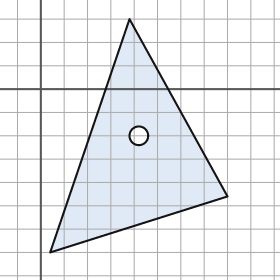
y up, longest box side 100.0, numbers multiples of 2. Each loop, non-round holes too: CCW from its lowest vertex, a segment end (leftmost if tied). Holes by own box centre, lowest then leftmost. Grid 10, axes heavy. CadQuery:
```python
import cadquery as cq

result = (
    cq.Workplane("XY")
    .moveTo(4.0, -70.0)
    .lineTo(80.0, -46.0)
    .lineTo(38.0, 30.0)
    .close()
    .moveTo(42.0, -20.0)
    .circle(4.0)
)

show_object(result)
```